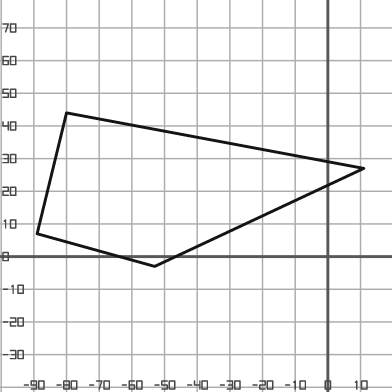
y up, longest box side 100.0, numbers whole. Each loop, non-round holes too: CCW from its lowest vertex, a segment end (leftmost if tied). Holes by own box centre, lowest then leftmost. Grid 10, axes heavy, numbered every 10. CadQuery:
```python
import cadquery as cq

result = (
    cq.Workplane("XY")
    .moveTo(-53.0, -3.0)
    .lineTo(11.0, 27.0)
    .lineTo(-80.0, 44.0)
    .lineTo(-89.0, 7.0)
    .close()
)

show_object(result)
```